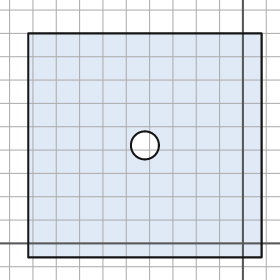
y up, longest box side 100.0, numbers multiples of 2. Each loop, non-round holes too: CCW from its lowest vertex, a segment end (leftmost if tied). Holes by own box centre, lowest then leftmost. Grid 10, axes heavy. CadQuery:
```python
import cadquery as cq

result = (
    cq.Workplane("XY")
    .moveTo(-92.0, -6.0)
    .lineTo(8.0, -6.0)
    .lineTo(8.0, 90.0)
    .lineTo(-92.0, 90.0)
    .close()
    .moveTo(-42.0, 42.0)
    .circle(6.0)
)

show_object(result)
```